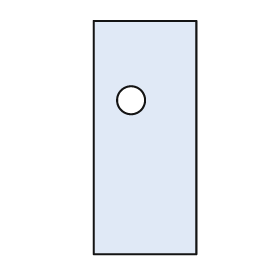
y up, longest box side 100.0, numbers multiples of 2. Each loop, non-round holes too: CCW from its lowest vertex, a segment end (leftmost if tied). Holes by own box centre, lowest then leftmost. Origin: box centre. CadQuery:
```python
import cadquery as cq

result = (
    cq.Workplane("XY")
    .moveTo(-22.0, -50.0)
    .lineTo(22.0, -50.0)
    .lineTo(22.0, 50.0)
    .lineTo(-22.0, 50.0)
    .close()
    .moveTo(-6.0, 16.0)
    .circle(6.0)
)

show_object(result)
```